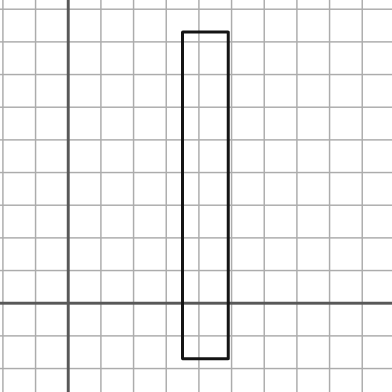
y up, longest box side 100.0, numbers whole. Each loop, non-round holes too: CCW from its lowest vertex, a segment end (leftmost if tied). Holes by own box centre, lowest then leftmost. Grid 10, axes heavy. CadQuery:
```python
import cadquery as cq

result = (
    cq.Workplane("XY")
    .moveTo(35.0, -17.0)
    .lineTo(49.0, -17.0)
    .lineTo(49.0, 83.0)
    .lineTo(35.0, 83.0)
    .close()
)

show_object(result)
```